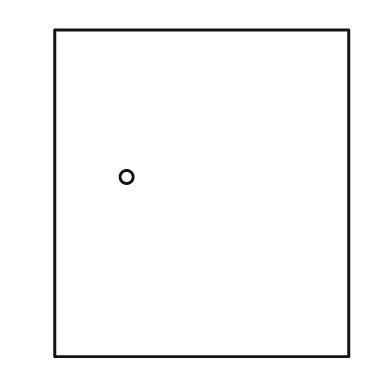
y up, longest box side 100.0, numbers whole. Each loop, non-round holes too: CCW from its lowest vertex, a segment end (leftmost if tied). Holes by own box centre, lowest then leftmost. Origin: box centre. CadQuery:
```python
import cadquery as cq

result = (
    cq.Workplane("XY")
    .moveTo(-45.0, -50.0)
    .lineTo(45.0, -50.0)
    .lineTo(45.0, 50.0)
    .lineTo(-45.0, 50.0)
    .close()
    .moveTo(-23.0, 5.0)
    .circle(2.0)
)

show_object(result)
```